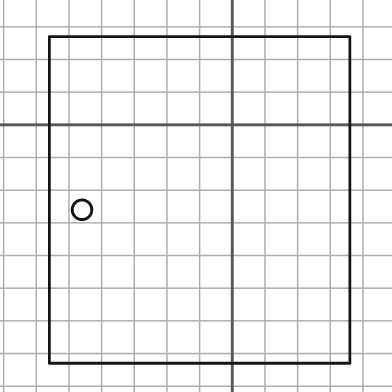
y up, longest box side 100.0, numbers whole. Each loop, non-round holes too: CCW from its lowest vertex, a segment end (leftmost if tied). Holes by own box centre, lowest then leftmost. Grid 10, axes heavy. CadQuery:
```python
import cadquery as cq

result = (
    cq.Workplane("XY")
    .moveTo(-56.0, -73.0)
    .lineTo(36.0, -73.0)
    .lineTo(36.0, 27.0)
    .lineTo(-56.0, 27.0)
    .close()
    .moveTo(-46.0, -26.0)
    .circle(3.0)
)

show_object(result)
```